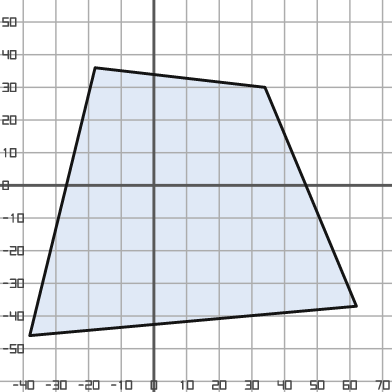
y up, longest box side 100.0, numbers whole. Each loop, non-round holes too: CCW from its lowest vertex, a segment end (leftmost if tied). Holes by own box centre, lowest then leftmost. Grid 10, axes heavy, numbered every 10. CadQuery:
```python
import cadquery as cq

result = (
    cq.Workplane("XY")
    .moveTo(-38.0, -46.0)
    .lineTo(62.0, -37.0)
    .lineTo(34.0, 30.0)
    .lineTo(-18.0, 36.0)
    .close()
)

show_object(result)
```